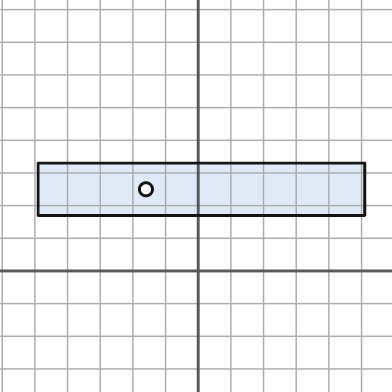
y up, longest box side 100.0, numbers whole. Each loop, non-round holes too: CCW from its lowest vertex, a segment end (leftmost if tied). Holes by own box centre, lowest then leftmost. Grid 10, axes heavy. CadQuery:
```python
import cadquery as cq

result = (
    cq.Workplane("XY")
    .moveTo(-49.0, 17.0)
    .lineTo(51.0, 17.0)
    .lineTo(51.0, 33.0)
    .lineTo(-49.0, 33.0)
    .close()
    .moveTo(-16.0, 25.0)
    .circle(2.0)
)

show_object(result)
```